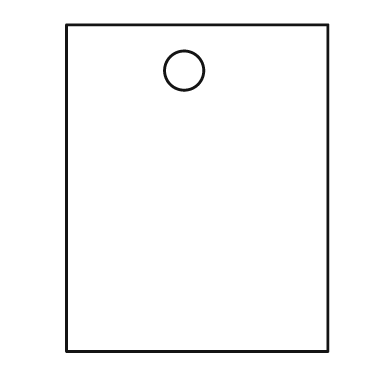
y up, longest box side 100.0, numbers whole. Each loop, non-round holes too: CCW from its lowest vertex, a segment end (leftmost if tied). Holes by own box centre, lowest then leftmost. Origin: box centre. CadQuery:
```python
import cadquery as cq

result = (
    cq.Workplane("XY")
    .moveTo(-40.0, -50.0)
    .lineTo(40.0, -50.0)
    .lineTo(40.0, 50.0)
    .lineTo(-40.0, 50.0)
    .close()
    .moveTo(-4.0, 36.0)
    .circle(6.0)
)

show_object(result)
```